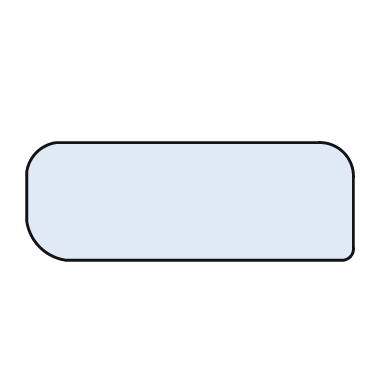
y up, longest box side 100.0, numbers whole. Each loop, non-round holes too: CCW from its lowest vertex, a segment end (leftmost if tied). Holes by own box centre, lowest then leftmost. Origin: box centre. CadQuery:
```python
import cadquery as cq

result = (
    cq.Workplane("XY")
    .moveTo(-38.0, -18.0)
    .lineTo(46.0, -18.0)
    .threePointArc((49.0, -17.0), (50.0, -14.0))
    .lineTo(50.0, 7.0)
    .threePointArc((47.0, 15.0), (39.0, 18.0))
    .lineTo(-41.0, 18.0)
    .threePointArc((-47.0, 15.0), (-50.0, 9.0))
    .lineTo(-50.0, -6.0)
    .threePointArc((-46.0, -14.0), (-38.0, -18.0))
    .close()
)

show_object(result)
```